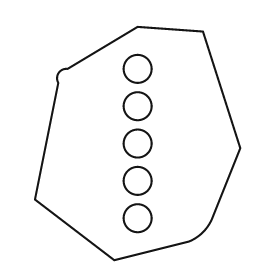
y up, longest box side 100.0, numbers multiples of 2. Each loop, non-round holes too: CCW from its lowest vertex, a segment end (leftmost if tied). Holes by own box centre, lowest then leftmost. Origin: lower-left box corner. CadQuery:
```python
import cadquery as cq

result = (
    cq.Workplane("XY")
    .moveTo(34.0, 0.0)
    .lineTo(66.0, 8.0)
    .threePointArc((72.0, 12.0), (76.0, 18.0))
    .lineTo(88.0, 48.0)
    .lineTo(72.0, 98.0)
    .lineTo(44.0, 100.0)
    .lineTo(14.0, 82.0)
    .threePointArc((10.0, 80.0), (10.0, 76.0))
    .lineTo(0.0, 26.0)
    .close()
    .moveTo(44.0, 18.0)
    .circle(6.0)
    .moveTo(44.0, 34.0)
    .circle(6.0)
    .moveTo(44.0, 50.0)
    .circle(6.0)
    .moveTo(44.0, 66.0)
    .circle(6.0)
    .moveTo(44.0, 82.0)
    .circle(6.0)
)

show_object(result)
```